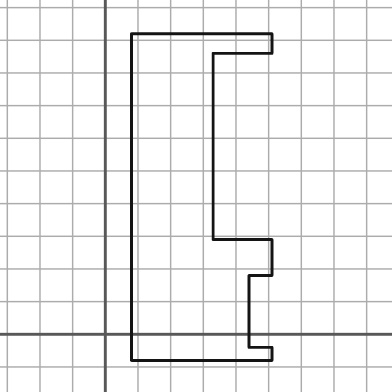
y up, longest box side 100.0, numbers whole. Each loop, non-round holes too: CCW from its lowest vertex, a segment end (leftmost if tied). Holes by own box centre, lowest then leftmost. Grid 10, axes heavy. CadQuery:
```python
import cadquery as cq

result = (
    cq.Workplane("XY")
    .moveTo(8.0, -8.0)
    .lineTo(51.0, -8.0)
    .lineTo(51.0, -4.0)
    .lineTo(44.0, -4.0)
    .lineTo(44.0, 18.0)
    .lineTo(51.0, 18.0)
    .lineTo(51.0, 29.0)
    .lineTo(33.0, 29.0)
    .lineTo(33.0, 86.0)
    .lineTo(51.0, 86.0)
    .lineTo(51.0, 92.0)
    .lineTo(8.0, 92.0)
    .close()
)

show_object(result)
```